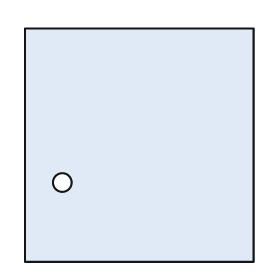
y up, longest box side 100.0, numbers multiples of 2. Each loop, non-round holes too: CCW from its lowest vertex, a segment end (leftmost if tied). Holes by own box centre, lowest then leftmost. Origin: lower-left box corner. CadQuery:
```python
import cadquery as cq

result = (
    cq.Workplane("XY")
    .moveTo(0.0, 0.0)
    .lineTo(98.0, 0.0)
    .lineTo(98.0, 100.0)
    .lineTo(0.0, 100.0)
    .close()
    .moveTo(16.0, 34.0)
    .circle(4.0)
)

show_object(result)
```